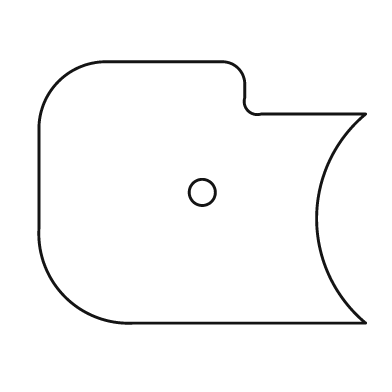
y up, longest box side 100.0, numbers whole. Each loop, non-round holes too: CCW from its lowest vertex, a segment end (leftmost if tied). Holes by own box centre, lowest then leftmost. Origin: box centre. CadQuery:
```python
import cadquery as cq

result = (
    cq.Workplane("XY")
    .moveTo(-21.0, -40.0)
    .lineTo(50.0, -40.0)
    .threePointArc((35.0, -8.0), (50.0, 24.0))
    .lineTo(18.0, 24.0)
    .threePointArc((14.0, 25.0), (13.0, 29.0))
    .lineTo(13.0, 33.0)
    .threePointArc((11.0, 38.0), (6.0, 40.0))
    .lineTo(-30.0, 40.0)
    .threePointArc((-44.0, 34.0), (-50.0, 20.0))
    .lineTo(-50.0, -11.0)
    .threePointArc((-42.0, -32.0), (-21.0, -40.0))
    .close()
    .moveTo(0.0, 0.0)
    .circle(4.0)
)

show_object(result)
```